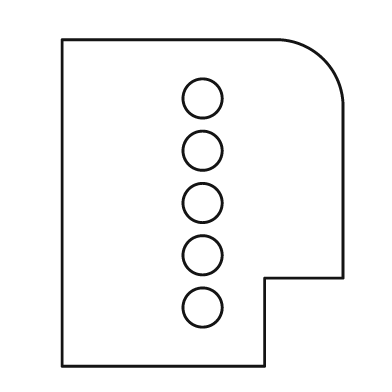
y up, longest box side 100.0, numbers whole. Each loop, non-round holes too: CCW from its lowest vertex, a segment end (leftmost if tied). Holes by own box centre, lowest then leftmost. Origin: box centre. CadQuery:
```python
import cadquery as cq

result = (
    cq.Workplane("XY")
    .moveTo(-43.0, -50.0)
    .lineTo(19.0, -50.0)
    .lineTo(19.0, -23.0)
    .lineTo(43.0, -23.0)
    .lineTo(43.0, 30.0)
    .threePointArc((37.0, 44.0), (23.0, 50.0))
    .lineTo(-43.0, 50.0)
    .close()
    .moveTo(0.0, -32.0)
    .circle(6.0)
    .moveTo(0.0, -16.0)
    .circle(6.0)
    .moveTo(0.0, 0.0)
    .circle(6.0)
    .moveTo(0.0, 16.0)
    .circle(6.0)
    .moveTo(0.0, 32.0)
    .circle(6.0)
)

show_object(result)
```